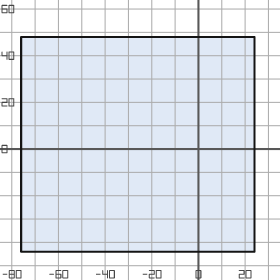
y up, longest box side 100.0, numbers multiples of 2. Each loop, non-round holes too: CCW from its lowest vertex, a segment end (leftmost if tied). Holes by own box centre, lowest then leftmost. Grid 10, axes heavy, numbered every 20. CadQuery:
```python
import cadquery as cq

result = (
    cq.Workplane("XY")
    .moveTo(-76.0, -44.0)
    .lineTo(24.0, -44.0)
    .lineTo(24.0, 48.0)
    .lineTo(-76.0, 48.0)
    .close()
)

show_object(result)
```